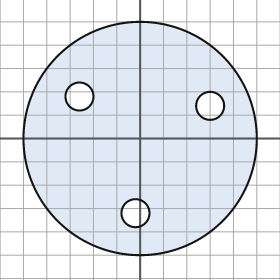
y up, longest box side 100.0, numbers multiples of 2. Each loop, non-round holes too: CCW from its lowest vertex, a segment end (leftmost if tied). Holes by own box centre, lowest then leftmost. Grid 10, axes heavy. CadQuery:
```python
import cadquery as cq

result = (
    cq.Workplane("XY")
    .moveTo(0.0, 0.0)
    .circle(50.0)
    .moveTo(-2.0, -32.0)
    .circle(6.0)
    .moveTo(30.0, 14.0)
    .circle(6.0)
    .moveTo(-26.0, 18.0)
    .circle(6.0)
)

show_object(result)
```